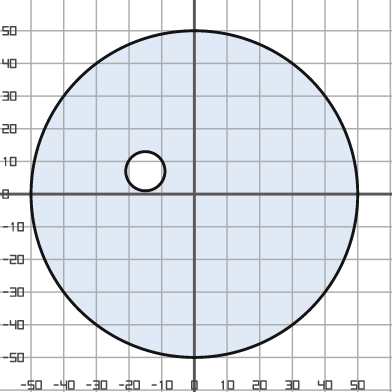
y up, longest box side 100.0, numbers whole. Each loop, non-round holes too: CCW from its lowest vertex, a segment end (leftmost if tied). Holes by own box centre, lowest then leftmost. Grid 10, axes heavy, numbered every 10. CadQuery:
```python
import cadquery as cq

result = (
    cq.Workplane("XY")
    .moveTo(0.0, 0.0)
    .circle(50.0)
    .moveTo(-15.0, 7.0)
    .circle(6.0)
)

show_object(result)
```